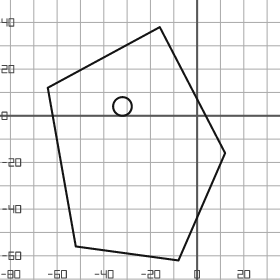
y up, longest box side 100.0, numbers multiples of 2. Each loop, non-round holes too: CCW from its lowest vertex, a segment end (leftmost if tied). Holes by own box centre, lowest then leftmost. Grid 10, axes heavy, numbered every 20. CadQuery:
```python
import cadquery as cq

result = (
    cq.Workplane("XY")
    .moveTo(-8.0, -62.0)
    .lineTo(12.0, -16.0)
    .lineTo(-16.0, 38.0)
    .lineTo(-64.0, 12.0)
    .lineTo(-52.0, -56.0)
    .close()
    .moveTo(-32.0, 4.0)
    .circle(4.0)
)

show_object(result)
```